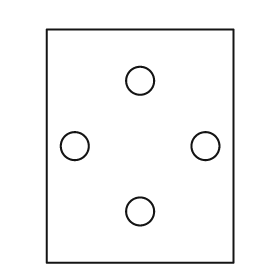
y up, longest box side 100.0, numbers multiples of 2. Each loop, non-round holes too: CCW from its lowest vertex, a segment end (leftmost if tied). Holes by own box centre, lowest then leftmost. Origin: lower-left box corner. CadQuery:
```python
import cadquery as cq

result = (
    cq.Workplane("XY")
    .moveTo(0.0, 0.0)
    .lineTo(80.0, 0.0)
    .lineTo(80.0, 100.0)
    .lineTo(0.0, 100.0)
    .close()
    .moveTo(40.0, 22.0)
    .circle(6.0)
    .moveTo(12.0, 50.0)
    .circle(6.0)
    .moveTo(68.0, 50.0)
    .circle(6.0)
    .moveTo(40.0, 78.0)
    .circle(6.0)
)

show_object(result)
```